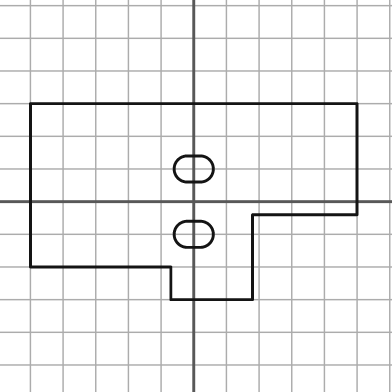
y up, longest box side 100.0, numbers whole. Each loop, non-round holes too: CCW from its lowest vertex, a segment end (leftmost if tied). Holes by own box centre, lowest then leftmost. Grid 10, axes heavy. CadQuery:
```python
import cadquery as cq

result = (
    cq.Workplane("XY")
    .moveTo(-7.0, -30.0)
    .lineTo(18.0, -30.0)
    .lineTo(18.0, -4.0)
    .lineTo(50.0, -4.0)
    .lineTo(50.0, 30.0)
    .lineTo(-50.0, 30.0)
    .lineTo(-50.0, -20.0)
    .lineTo(-7.0, -20.0)
    .close()
    .moveTo(-2.0, -14.0)
    .lineTo(2.0, -14.0)
    .threePointArc((6.0, -10.0), (2.0, -6.0))
    .lineTo(-2.0, -6.0)
    .threePointArc((-6.0, -10.0), (-2.0, -14.0))
    .close()
    .moveTo(-2.0, 6.0)
    .lineTo(2.0, 6.0)
    .threePointArc((6.0, 10.0), (2.0, 14.0))
    .lineTo(-2.0, 14.0)
    .threePointArc((-6.0, 10.0), (-2.0, 6.0))
    .close()
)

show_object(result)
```